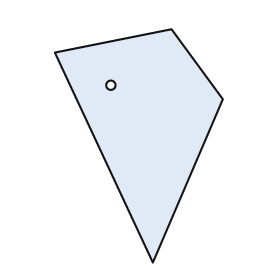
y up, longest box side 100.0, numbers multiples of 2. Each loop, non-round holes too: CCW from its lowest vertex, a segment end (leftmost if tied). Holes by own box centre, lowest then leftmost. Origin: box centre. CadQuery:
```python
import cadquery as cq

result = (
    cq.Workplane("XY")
    .moveTo(6.0, -50.0)
    .lineTo(36.0, 20.0)
    .lineTo(14.0, 50.0)
    .lineTo(-36.0, 40.0)
    .close()
    .moveTo(-12.0, 26.0)
    .circle(2.0)
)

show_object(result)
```